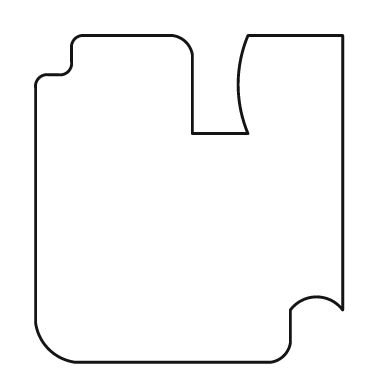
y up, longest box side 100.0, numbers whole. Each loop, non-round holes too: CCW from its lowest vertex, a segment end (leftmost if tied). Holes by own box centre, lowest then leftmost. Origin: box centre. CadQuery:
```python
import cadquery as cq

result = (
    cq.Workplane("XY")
    .moveTo(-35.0, -50.0)
    .lineTo(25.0, -50.0)
    .threePointArc((29.0, -48.0), (31.0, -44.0))
    .lineTo(31.0, -34.0)
    .threePointArc((39.0, -30.0), (47.0, -34.0))
    .lineTo(47.0, 50.0)
    .lineTo(18.0, 50.0)
    .threePointArc((15.0, 35.0), (18.0, 20.0))
    .lineTo(1.0, 20.0)
    .lineTo(1.0, 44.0)
    .threePointArc((-1.0, 48.0), (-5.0, 50.0))
    .lineTo(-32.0, 50.0)
    .threePointArc((-35.0, 49.0), (-36.0, 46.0))
    .lineTo(-36.0, 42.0)
    .threePointArc((-37.0, 39.0), (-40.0, 38.0))
    .lineTo(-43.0, 38.0)
    .threePointArc((-46.0, 37.0), (-47.0, 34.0))
    .lineTo(-47.0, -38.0)
    .threePointArc((-43.0, -46.0), (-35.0, -50.0))
    .close()
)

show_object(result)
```